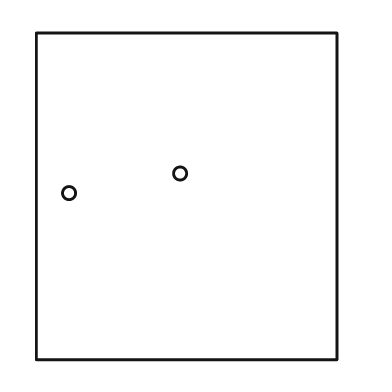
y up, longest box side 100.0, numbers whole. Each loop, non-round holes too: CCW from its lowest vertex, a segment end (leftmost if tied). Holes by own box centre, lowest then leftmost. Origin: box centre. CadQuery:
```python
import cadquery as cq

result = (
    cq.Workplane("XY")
    .moveTo(-46.0, -50.0)
    .lineTo(46.0, -50.0)
    .lineTo(46.0, 50.0)
    .lineTo(-46.0, 50.0)
    .close()
    .moveTo(-36.0, 1.0)
    .circle(2.0)
    .moveTo(-2.0, 7.0)
    .circle(2.0)
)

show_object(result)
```